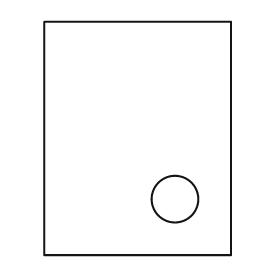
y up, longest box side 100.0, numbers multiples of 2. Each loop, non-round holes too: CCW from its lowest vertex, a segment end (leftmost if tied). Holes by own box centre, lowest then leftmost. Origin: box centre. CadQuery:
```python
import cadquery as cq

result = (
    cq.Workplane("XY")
    .moveTo(-40.0, -50.0)
    .lineTo(40.0, -50.0)
    .lineTo(40.0, 50.0)
    .lineTo(-40.0, 50.0)
    .close()
    .moveTo(16.0, -26.0)
    .circle(10.0)
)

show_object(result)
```